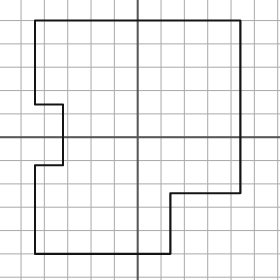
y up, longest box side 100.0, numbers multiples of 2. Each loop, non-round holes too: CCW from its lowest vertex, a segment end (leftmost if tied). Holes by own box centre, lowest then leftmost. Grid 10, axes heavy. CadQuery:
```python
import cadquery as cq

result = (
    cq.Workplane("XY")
    .moveTo(-44.0, -50.0)
    .lineTo(14.0, -50.0)
    .lineTo(14.0, -24.0)
    .lineTo(44.0, -24.0)
    .lineTo(44.0, 50.0)
    .lineTo(-44.0, 50.0)
    .lineTo(-44.0, 14.0)
    .lineTo(-32.0, 14.0)
    .lineTo(-32.0, -12.0)
    .lineTo(-44.0, -12.0)
    .close()
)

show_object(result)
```